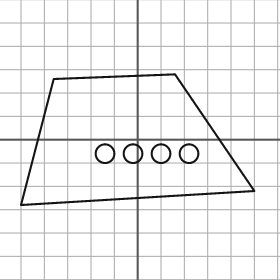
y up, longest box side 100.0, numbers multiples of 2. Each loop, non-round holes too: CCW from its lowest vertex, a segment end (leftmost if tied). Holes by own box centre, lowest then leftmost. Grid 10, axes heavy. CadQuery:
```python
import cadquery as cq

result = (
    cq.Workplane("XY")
    .moveTo(-50.0, -28.0)
    .lineTo(50.0, -22.0)
    .lineTo(16.0, 28.0)
    .lineTo(-36.0, 26.0)
    .close()
    .moveTo(-14.0, -6.0)
    .circle(4.0)
    .moveTo(-2.0, -6.0)
    .circle(4.0)
    .moveTo(10.0, -6.0)
    .circle(4.0)
    .moveTo(22.0, -6.0)
    .circle(4.0)
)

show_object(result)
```